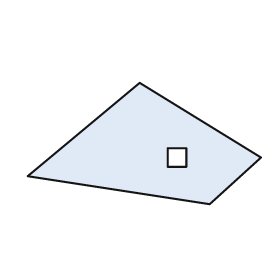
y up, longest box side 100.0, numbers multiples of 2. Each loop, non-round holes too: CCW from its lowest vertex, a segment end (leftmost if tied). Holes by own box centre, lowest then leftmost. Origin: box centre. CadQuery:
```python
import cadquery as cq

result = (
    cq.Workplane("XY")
    .moveTo(28.0, -26.0)
    .lineTo(50.0, -6.0)
    .lineTo(-2.0, 26.0)
    .lineTo(-50.0, -14.0)
    .close()
    .moveTo(10.0, -10.0)
    .lineTo(18.0, -10.0)
    .lineTo(18.0, -2.0)
    .lineTo(10.0, -2.0)
    .close()
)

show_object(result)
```